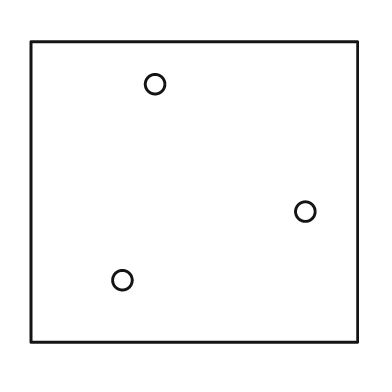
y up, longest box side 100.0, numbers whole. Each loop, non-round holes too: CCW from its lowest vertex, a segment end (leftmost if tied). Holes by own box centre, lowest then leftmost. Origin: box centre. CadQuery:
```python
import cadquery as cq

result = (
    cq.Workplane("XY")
    .moveTo(-50.0, -46.0)
    .lineTo(50.0, -46.0)
    .lineTo(50.0, 46.0)
    .lineTo(-50.0, 46.0)
    .close()
    .moveTo(-22.0, -27.0)
    .circle(3.0)
    .moveTo(34.0, -6.0)
    .circle(3.0)
    .moveTo(-12.0, 33.0)
    .circle(3.0)
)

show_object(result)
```